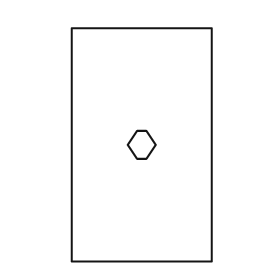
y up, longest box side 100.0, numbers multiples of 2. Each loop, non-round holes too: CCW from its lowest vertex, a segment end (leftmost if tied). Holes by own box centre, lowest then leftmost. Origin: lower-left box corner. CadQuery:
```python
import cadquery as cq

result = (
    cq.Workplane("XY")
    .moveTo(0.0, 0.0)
    .lineTo(60.0, 0.0)
    .lineTo(60.0, 100.0)
    .lineTo(0.0, 100.0)
    .close()
    .moveTo(28.0, 44.0)
    .lineTo(32.0, 44.0)
    .lineTo(36.0, 50.0)
    .lineTo(32.0, 56.0)
    .lineTo(28.0, 56.0)
    .lineTo(24.0, 50.0)
    .close()
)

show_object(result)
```